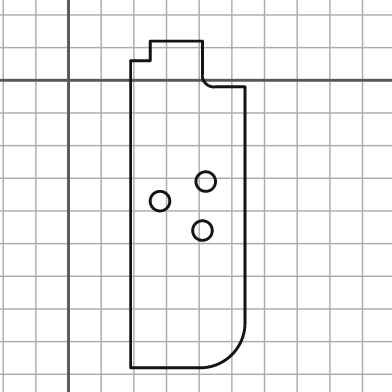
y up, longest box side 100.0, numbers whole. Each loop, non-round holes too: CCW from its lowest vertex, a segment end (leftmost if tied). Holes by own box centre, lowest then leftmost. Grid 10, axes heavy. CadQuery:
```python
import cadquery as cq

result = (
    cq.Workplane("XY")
    .moveTo(19.0, -88.0)
    .lineTo(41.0, -88.0)
    .threePointArc((50.0, -84.0), (54.0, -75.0))
    .lineTo(54.0, -2.0)
    .lineTo(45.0, -2.0)
    .threePointArc((42.0, -1.0), (41.0, 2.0))
    .lineTo(41.0, 12.0)
    .lineTo(25.0, 12.0)
    .lineTo(25.0, 6.0)
    .lineTo(19.0, 6.0)
    .close()
    .moveTo(41.0, -46.0)
    .circle(3.0)
    .moveTo(28.0, -37.0)
    .circle(3.0)
    .moveTo(42.0, -31.0)
    .circle(3.0)
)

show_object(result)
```